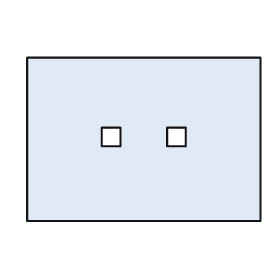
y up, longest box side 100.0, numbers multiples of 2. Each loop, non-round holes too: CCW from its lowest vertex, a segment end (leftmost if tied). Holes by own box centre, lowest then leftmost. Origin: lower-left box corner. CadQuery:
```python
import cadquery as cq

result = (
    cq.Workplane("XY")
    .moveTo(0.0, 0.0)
    .lineTo(100.0, 0.0)
    .lineTo(100.0, 70.0)
    .lineTo(0.0, 70.0)
    .close()
    .moveTo(32.0, 32.0)
    .lineTo(40.0, 32.0)
    .lineTo(40.0, 40.0)
    .lineTo(32.0, 40.0)
    .close()
    .moveTo(60.0, 32.0)
    .lineTo(68.0, 32.0)
    .lineTo(68.0, 40.0)
    .lineTo(60.0, 40.0)
    .close()
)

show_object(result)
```